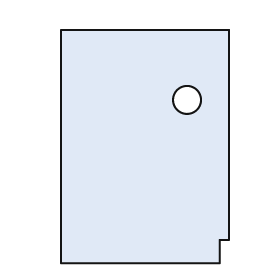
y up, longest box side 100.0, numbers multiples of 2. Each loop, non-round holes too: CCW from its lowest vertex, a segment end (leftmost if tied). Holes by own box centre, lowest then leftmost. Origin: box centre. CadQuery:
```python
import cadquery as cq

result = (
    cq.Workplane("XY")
    .moveTo(-36.0, -50.0)
    .lineTo(32.0, -50.0)
    .lineTo(32.0, -40.0)
    .lineTo(36.0, -40.0)
    .lineTo(36.0, 50.0)
    .lineTo(-36.0, 50.0)
    .close()
    .moveTo(18.0, 20.0)
    .circle(6.0)
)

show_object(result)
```